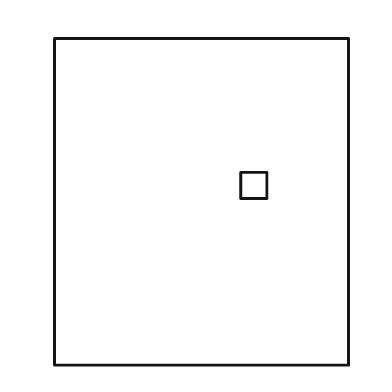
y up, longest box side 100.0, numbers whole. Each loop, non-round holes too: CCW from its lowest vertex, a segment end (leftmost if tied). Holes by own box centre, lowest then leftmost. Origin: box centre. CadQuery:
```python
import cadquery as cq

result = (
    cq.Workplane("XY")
    .moveTo(-45.0, -50.0)
    .lineTo(45.0, -50.0)
    .lineTo(45.0, 50.0)
    .lineTo(-45.0, 50.0)
    .close()
    .moveTo(12.0, 1.0)
    .lineTo(20.0, 1.0)
    .lineTo(20.0, 9.0)
    .lineTo(12.0, 9.0)
    .close()
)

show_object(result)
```